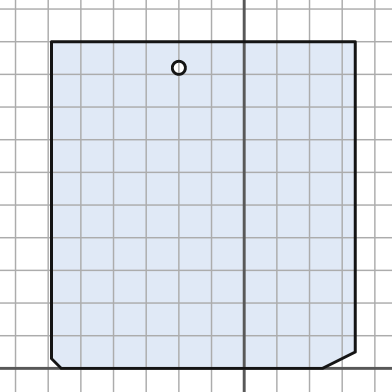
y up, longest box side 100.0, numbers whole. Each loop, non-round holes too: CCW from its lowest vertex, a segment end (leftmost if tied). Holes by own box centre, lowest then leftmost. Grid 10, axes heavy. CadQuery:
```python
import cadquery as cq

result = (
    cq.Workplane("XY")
    .moveTo(-56.0, 0.0)
    .lineTo(24.0, 0.0)
    .lineTo(34.0, 5.0)
    .lineTo(34.0, 100.0)
    .lineTo(-59.0, 100.0)
    .lineTo(-59.0, 3.0)
    .close()
    .moveTo(-20.0, 92.0)
    .circle(2.0)
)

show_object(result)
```